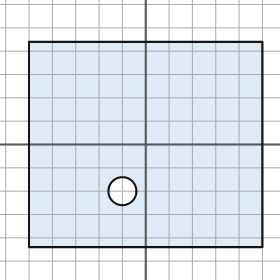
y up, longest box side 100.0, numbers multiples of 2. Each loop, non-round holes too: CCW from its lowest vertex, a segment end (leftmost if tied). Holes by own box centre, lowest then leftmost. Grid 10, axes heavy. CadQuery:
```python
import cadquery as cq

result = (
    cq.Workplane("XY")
    .moveTo(-50.0, -44.0)
    .lineTo(50.0, -44.0)
    .lineTo(50.0, 44.0)
    .lineTo(-50.0, 44.0)
    .close()
    .moveTo(-10.0, -20.0)
    .circle(6.0)
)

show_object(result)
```